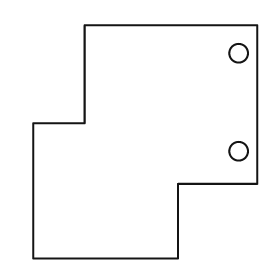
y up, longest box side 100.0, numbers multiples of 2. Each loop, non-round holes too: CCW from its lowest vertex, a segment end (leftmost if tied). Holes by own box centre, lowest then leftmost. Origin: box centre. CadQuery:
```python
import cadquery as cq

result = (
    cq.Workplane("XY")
    .moveTo(-48.0, -50.0)
    .lineTo(14.0, -50.0)
    .lineTo(14.0, -18.0)
    .lineTo(48.0, -18.0)
    .lineTo(48.0, 50.0)
    .lineTo(-26.0, 50.0)
    .lineTo(-26.0, 8.0)
    .lineTo(-48.0, 8.0)
    .close()
    .moveTo(40.0, -4.0)
    .circle(4.0)
    .moveTo(40.0, 38.0)
    .circle(4.0)
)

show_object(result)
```